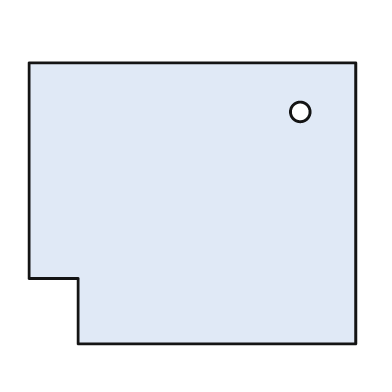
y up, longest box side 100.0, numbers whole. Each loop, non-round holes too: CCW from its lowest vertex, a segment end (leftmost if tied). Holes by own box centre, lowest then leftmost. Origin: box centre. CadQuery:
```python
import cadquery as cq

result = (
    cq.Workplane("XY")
    .moveTo(-35.0, -43.0)
    .lineTo(50.0, -43.0)
    .lineTo(50.0, 43.0)
    .lineTo(-50.0, 43.0)
    .lineTo(-50.0, -23.0)
    .lineTo(-35.0, -23.0)
    .close()
    .moveTo(33.0, 28.0)
    .circle(3.0)
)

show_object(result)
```